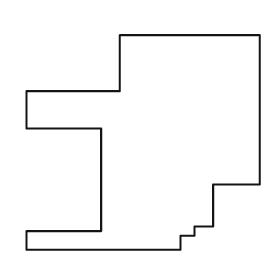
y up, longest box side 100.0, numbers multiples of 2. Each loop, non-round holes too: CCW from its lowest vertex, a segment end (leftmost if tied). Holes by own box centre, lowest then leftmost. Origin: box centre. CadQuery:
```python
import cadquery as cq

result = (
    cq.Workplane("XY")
    .moveTo(-50.0, -46.0)
    .lineTo(16.0, -46.0)
    .lineTo(16.0, -40.0)
    .lineTo(22.0, -40.0)
    .lineTo(22.0, -36.0)
    .lineTo(30.0, -36.0)
    .lineTo(30.0, -18.0)
    .lineTo(50.0, -18.0)
    .lineTo(50.0, 46.0)
    .lineTo(-10.0, 46.0)
    .lineTo(-10.0, 22.0)
    .lineTo(-50.0, 22.0)
    .lineTo(-50.0, 6.0)
    .lineTo(-18.0, 6.0)
    .lineTo(-18.0, -38.0)
    .lineTo(-50.0, -38.0)
    .close()
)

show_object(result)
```